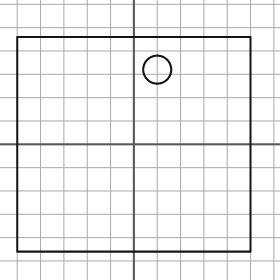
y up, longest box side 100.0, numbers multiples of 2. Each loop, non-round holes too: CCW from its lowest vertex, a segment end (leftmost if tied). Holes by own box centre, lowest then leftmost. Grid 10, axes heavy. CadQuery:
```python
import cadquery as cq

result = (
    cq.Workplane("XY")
    .moveTo(-50.0, -46.0)
    .lineTo(50.0, -46.0)
    .lineTo(50.0, 46.0)
    .lineTo(-50.0, 46.0)
    .close()
    .moveTo(10.0, 32.0)
    .circle(6.0)
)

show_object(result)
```